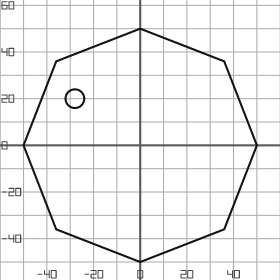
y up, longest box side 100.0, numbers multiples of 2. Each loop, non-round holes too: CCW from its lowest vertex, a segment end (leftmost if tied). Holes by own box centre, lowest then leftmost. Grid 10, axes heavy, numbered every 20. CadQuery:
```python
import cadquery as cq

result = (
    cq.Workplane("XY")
    .moveTo(0.0, -50.0)
    .lineTo(36.0, -36.0)
    .lineTo(50.0, 0.0)
    .lineTo(36.0, 36.0)
    .lineTo(0.0, 50.0)
    .lineTo(-36.0, 36.0)
    .lineTo(-50.0, 0.0)
    .lineTo(-36.0, -36.0)
    .close()
    .moveTo(-28.0, 20.0)
    .circle(4.0)
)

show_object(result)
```